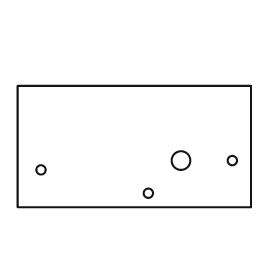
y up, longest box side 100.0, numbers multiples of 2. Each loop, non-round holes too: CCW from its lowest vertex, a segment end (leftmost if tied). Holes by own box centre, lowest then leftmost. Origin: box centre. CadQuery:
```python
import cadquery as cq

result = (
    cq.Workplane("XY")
    .moveTo(-50.0, -26.0)
    .lineTo(50.0, -26.0)
    .lineTo(50.0, 26.0)
    .lineTo(-50.0, 26.0)
    .close()
    .moveTo(6.0, -20.0)
    .circle(2.0)
    .moveTo(-40.0, -10.0)
    .circle(2.0)
    .moveTo(20.0, -6.0)
    .circle(4.0)
    .moveTo(42.0, -6.0)
    .circle(2.0)
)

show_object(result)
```